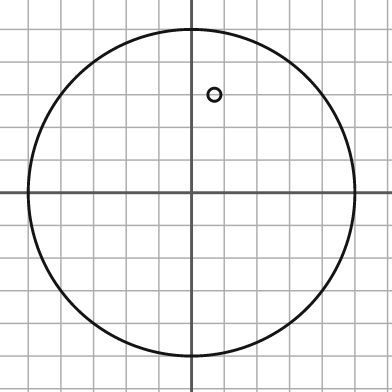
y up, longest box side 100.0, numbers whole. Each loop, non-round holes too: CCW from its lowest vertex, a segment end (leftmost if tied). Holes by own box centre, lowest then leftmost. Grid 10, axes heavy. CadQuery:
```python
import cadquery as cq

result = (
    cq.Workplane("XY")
    .moveTo(0.0, 0.0)
    .circle(50.0)
    .moveTo(7.0, 30.0)
    .circle(2.0)
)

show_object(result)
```